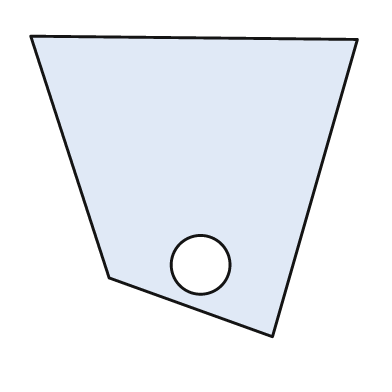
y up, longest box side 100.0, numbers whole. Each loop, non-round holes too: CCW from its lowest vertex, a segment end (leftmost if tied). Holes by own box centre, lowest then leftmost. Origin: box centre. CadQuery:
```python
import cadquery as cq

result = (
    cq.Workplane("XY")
    .moveTo(24.0, -46.0)
    .lineTo(50.0, 45.0)
    .lineTo(-50.0, 46.0)
    .lineTo(-26.0, -28.0)
    .close()
    .moveTo(2.0, -24.0)
    .circle(9.0)
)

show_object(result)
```